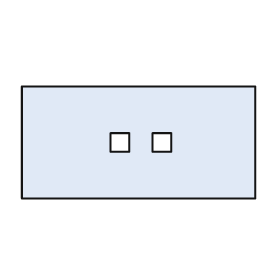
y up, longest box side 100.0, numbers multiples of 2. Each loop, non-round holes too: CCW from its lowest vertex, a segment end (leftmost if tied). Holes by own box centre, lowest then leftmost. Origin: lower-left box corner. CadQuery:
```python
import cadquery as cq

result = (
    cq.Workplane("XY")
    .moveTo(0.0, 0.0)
    .lineTo(100.0, 0.0)
    .lineTo(100.0, 48.0)
    .lineTo(0.0, 48.0)
    .close()
    .moveTo(38.0, 20.0)
    .lineTo(46.0, 20.0)
    .lineTo(46.0, 28.0)
    .lineTo(38.0, 28.0)
    .close()
    .moveTo(56.0, 20.0)
    .lineTo(64.0, 20.0)
    .lineTo(64.0, 28.0)
    .lineTo(56.0, 28.0)
    .close()
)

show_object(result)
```